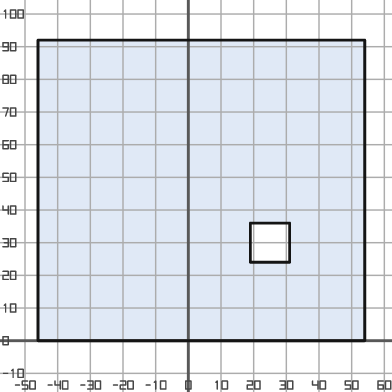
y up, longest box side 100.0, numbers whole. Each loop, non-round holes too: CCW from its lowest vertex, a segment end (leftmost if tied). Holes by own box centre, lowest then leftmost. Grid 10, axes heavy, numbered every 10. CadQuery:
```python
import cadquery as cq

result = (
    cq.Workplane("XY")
    .moveTo(-46.0, 0.0)
    .lineTo(54.0, 0.0)
    .lineTo(54.0, 92.0)
    .lineTo(-46.0, 92.0)
    .close()
    .moveTo(19.0, 24.0)
    .lineTo(31.0, 24.0)
    .lineTo(31.0, 36.0)
    .lineTo(19.0, 36.0)
    .close()
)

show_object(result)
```